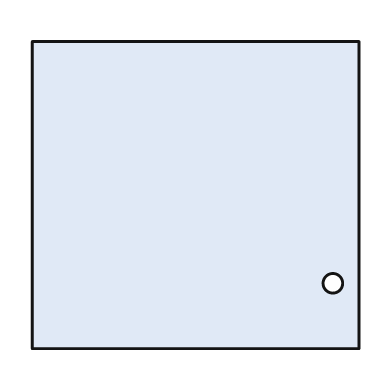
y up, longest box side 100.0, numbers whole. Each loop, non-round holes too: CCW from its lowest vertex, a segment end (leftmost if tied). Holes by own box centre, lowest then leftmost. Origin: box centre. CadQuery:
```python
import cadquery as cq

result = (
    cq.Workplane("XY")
    .moveTo(-50.0, -47.0)
    .lineTo(50.0, -47.0)
    .lineTo(50.0, 47.0)
    .lineTo(-50.0, 47.0)
    .close()
    .moveTo(42.0, -27.0)
    .circle(3.0)
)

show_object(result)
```